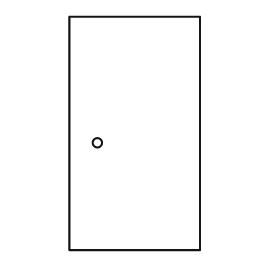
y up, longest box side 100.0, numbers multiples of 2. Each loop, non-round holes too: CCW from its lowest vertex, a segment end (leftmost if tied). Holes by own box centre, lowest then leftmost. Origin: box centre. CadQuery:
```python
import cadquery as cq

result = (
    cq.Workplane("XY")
    .moveTo(-28.0, -50.0)
    .lineTo(28.0, -50.0)
    .lineTo(28.0, 50.0)
    .lineTo(-28.0, 50.0)
    .close()
    .moveTo(-16.0, -4.0)
    .circle(2.0)
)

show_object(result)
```